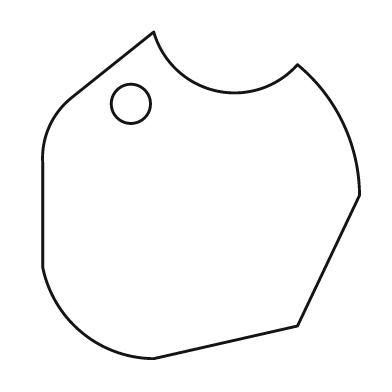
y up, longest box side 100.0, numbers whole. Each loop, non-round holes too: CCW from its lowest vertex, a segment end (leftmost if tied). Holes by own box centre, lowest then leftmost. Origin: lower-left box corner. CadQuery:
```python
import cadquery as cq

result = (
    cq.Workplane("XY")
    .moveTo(34.0, 0.0)
    .lineTo(78.0, 10.0)
    .lineTo(97.0, 50.0)
    .threePointArc((92.0, 72.0), (78.0, 90.0))
    .threePointArc((53.0, 82.0), (34.0, 100.0))
    .lineTo(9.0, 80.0)
    .threePointArc((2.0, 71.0), (0.0, 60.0))
    .lineTo(0.0, 28.0)
    .threePointArc((12.0, 8.0), (34.0, 0.0))
    .close()
    .moveTo(27.0, 78.0)
    .circle(6.0)
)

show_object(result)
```